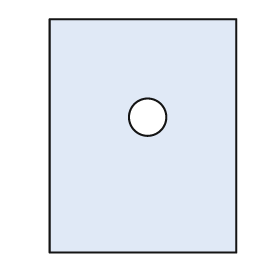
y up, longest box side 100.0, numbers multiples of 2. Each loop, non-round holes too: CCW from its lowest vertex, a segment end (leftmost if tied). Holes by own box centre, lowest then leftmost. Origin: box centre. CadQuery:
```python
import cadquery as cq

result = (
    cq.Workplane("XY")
    .moveTo(-40.0, -50.0)
    .lineTo(40.0, -50.0)
    .lineTo(40.0, 50.0)
    .lineTo(-40.0, 50.0)
    .close()
    .moveTo(2.0, 8.0)
    .circle(8.0)
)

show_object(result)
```